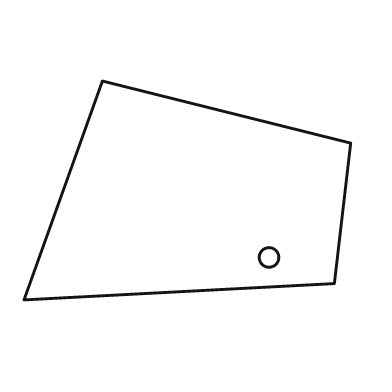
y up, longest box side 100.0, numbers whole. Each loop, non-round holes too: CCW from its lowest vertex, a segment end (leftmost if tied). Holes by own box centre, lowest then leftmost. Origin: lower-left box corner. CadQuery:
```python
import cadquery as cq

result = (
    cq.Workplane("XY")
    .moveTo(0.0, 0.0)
    .lineTo(95.0, 5.0)
    .lineTo(100.0, 48.0)
    .lineTo(24.0, 67.0)
    .close()
    .moveTo(75.0, 13.0)
    .circle(3.0)
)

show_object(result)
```